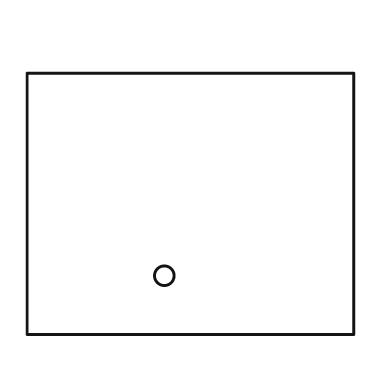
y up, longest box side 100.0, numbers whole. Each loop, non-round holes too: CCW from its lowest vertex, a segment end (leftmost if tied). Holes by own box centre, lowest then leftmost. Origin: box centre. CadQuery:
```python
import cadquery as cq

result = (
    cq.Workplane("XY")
    .moveTo(-50.0, -40.0)
    .lineTo(50.0, -40.0)
    .lineTo(50.0, 40.0)
    .lineTo(-50.0, 40.0)
    .close()
    .moveTo(-8.0, -22.0)
    .circle(3.0)
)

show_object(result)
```